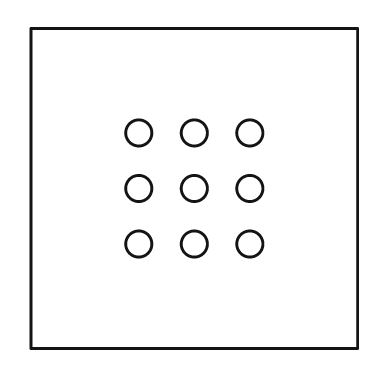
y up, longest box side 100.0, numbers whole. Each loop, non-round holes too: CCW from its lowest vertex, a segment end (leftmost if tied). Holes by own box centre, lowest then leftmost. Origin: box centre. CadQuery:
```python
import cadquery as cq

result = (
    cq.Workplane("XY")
    .moveTo(-50.0, -49.0)
    .lineTo(50.0, -49.0)
    .lineTo(50.0, 49.0)
    .lineTo(-50.0, 49.0)
    .close()
    .moveTo(-17.0, -17.0)
    .circle(4.0)
    .moveTo(0.0, -17.0)
    .circle(4.0)
    .moveTo(17.0, -17.0)
    .circle(4.0)
    .moveTo(-17.0, 0.0)
    .circle(4.0)
    .moveTo(0.0, 0.0)
    .circle(4.0)
    .moveTo(17.0, 0.0)
    .circle(4.0)
    .moveTo(-17.0, 17.0)
    .circle(4.0)
    .moveTo(0.0, 17.0)
    .circle(4.0)
    .moveTo(17.0, 17.0)
    .circle(4.0)
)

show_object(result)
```